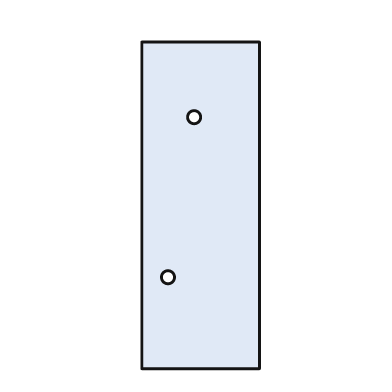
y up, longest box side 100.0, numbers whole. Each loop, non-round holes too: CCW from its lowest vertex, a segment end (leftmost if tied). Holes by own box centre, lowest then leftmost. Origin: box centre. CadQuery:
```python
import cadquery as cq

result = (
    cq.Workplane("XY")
    .moveTo(-18.0, -50.0)
    .lineTo(18.0, -50.0)
    .lineTo(18.0, 50.0)
    .lineTo(-18.0, 50.0)
    .close()
    .moveTo(-10.0, -22.0)
    .circle(2.0)
    .moveTo(-2.0, 27.0)
    .circle(2.0)
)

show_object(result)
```